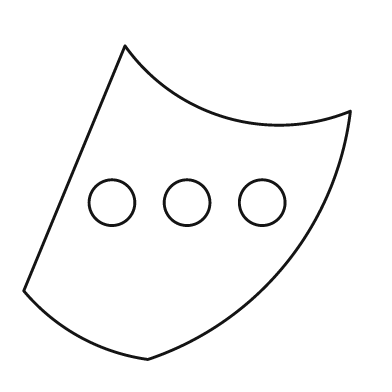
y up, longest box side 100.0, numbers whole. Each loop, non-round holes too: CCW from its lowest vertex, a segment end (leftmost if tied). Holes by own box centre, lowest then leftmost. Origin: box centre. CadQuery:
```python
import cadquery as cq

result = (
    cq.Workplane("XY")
    .moveTo(-12.0, -48.0)
    .threePointArc((30.0, -19.0), (50.0, 28.0))
    .threePointArc((12.0, 26.0), (-19.0, 48.0))
    .lineTo(-50.0, -27.0)
    .threePointArc((-33.0, -41.0), (-12.0, -48.0))
    .close()
    .moveTo(-23.0, 0.0)
    .circle(7.0)
    .moveTo(0.0, 0.0)
    .circle(7.0)
    .moveTo(23.0, 0.0)
    .circle(7.0)
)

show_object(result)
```